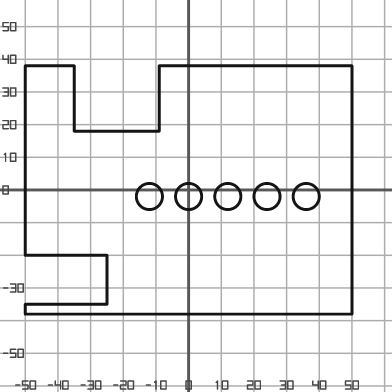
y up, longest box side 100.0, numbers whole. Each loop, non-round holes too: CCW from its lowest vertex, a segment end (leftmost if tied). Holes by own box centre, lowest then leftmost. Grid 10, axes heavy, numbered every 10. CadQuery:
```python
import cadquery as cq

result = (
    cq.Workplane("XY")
    .moveTo(-50.0, -38.0)
    .lineTo(50.0, -38.0)
    .lineTo(50.0, 38.0)
    .lineTo(-9.0, 38.0)
    .lineTo(-9.0, 18.0)
    .lineTo(-35.0, 18.0)
    .lineTo(-35.0, 38.0)
    .lineTo(-50.0, 38.0)
    .lineTo(-50.0, -20.0)
    .lineTo(-25.0, -20.0)
    .lineTo(-25.0, -35.0)
    .lineTo(-50.0, -35.0)
    .close()
    .moveTo(-12.0, -2.0)
    .circle(4.0)
    .moveTo(0.0, -2.0)
    .circle(4.0)
    .moveTo(12.0, -2.0)
    .circle(4.0)
    .moveTo(24.0, -2.0)
    .circle(4.0)
    .moveTo(36.0, -2.0)
    .circle(4.0)
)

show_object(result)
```